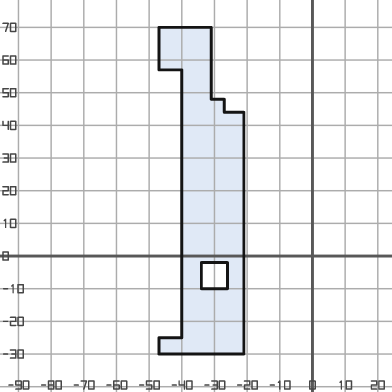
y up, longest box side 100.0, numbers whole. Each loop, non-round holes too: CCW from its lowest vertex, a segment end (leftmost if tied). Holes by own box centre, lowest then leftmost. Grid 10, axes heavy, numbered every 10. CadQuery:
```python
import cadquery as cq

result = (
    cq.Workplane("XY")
    .moveTo(-47.0, -30.0)
    .lineTo(-21.0, -30.0)
    .lineTo(-21.0, 44.0)
    .lineTo(-27.0, 44.0)
    .lineTo(-27.0, 48.0)
    .lineTo(-31.0, 48.0)
    .lineTo(-31.0, 70.0)
    .lineTo(-47.0, 70.0)
    .lineTo(-47.0, 57.0)
    .lineTo(-40.0, 57.0)
    .lineTo(-40.0, -25.0)
    .lineTo(-47.0, -25.0)
    .close()
    .moveTo(-34.0, -10.0)
    .lineTo(-26.0, -10.0)
    .lineTo(-26.0, -2.0)
    .lineTo(-34.0, -2.0)
    .close()
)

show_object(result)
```